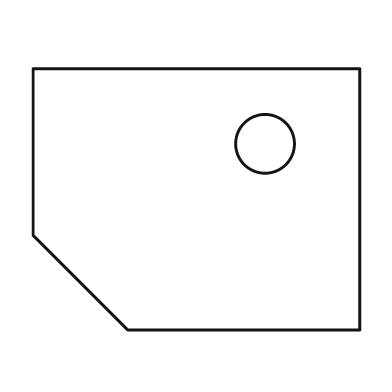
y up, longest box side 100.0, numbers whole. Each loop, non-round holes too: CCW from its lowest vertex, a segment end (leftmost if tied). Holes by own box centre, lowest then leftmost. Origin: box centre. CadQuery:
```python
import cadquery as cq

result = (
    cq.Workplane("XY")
    .moveTo(-21.0, -40.0)
    .lineTo(50.0, -40.0)
    .lineTo(50.0, 40.0)
    .lineTo(-50.0, 40.0)
    .lineTo(-50.0, -11.0)
    .close()
    .moveTo(21.0, 17.0)
    .circle(9.0)
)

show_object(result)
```